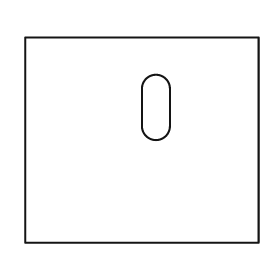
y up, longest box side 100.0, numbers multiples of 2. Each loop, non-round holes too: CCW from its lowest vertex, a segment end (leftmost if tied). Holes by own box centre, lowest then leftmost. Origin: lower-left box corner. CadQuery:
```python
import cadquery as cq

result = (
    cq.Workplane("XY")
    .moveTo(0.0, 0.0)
    .lineTo(100.0, 0.0)
    .lineTo(100.0, 88.0)
    .lineTo(0.0, 88.0)
    .close()
    .moveTo(50.0, 50.0)
    .threePointArc((56.0, 44.0), (62.0, 50.0))
    .lineTo(62.0, 66.0)
    .threePointArc((56.0, 72.0), (50.0, 66.0))
    .close()
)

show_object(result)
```